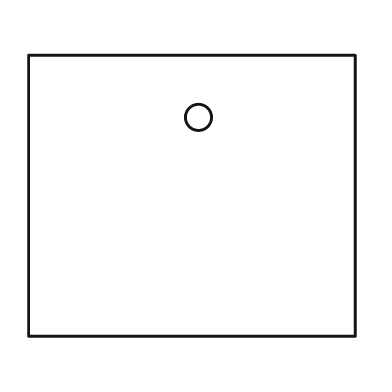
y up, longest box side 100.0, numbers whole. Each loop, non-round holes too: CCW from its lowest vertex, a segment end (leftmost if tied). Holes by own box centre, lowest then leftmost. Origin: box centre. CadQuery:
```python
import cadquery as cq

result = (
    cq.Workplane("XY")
    .moveTo(-50.0, -43.0)
    .lineTo(50.0, -43.0)
    .lineTo(50.0, 43.0)
    .lineTo(-50.0, 43.0)
    .close()
    .moveTo(2.0, 24.0)
    .circle(4.0)
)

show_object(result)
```